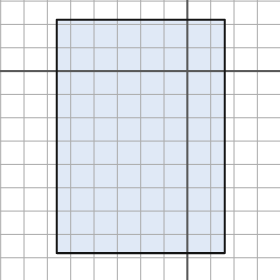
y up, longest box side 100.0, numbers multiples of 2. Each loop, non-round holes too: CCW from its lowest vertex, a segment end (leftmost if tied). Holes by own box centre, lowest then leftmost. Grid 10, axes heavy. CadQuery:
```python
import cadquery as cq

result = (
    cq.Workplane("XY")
    .moveTo(-56.0, -78.0)
    .lineTo(16.0, -78.0)
    .lineTo(16.0, 22.0)
    .lineTo(-56.0, 22.0)
    .close()
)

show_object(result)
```